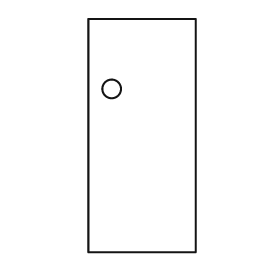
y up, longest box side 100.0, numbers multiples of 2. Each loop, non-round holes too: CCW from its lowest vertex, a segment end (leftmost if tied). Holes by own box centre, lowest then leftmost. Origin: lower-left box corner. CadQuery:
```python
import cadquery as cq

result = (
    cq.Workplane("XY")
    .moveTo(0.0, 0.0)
    .lineTo(46.0, 0.0)
    .lineTo(46.0, 100.0)
    .lineTo(0.0, 100.0)
    .close()
    .moveTo(10.0, 70.0)
    .circle(4.0)
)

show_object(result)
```